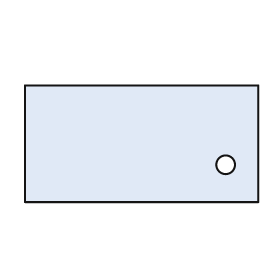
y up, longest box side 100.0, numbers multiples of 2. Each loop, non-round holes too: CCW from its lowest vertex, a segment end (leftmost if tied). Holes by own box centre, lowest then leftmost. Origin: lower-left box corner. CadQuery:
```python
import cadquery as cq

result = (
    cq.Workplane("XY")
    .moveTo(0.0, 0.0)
    .lineTo(100.0, 0.0)
    .lineTo(100.0, 50.0)
    .lineTo(0.0, 50.0)
    .close()
    .moveTo(86.0, 16.0)
    .circle(4.0)
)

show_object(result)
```